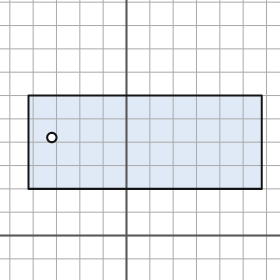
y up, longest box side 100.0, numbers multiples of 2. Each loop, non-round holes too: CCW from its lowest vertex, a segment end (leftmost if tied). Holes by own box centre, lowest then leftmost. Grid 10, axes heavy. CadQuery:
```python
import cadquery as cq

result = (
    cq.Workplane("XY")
    .moveTo(-42.0, 20.0)
    .lineTo(58.0, 20.0)
    .lineTo(58.0, 60.0)
    .lineTo(-42.0, 60.0)
    .close()
    .moveTo(-32.0, 42.0)
    .circle(2.0)
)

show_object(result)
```